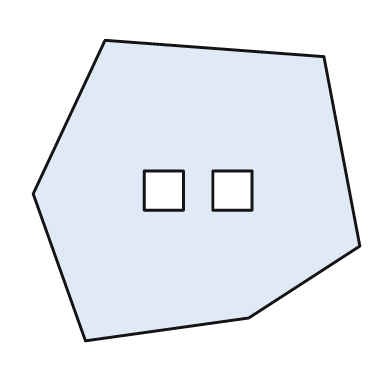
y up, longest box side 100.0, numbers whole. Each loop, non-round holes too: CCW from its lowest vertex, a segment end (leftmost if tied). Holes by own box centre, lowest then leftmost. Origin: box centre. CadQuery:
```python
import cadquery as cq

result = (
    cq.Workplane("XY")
    .moveTo(-34.0, -46.0)
    .lineTo(16.0, -39.0)
    .lineTo(50.0, -17.0)
    .lineTo(39.0, 41.0)
    .lineTo(-28.0, 46.0)
    .lineTo(-50.0, -1.0)
    .close()
    .moveTo(-16.0, -6.0)
    .lineTo(-4.0, -6.0)
    .lineTo(-4.0, 6.0)
    .lineTo(-16.0, 6.0)
    .close()
    .moveTo(5.0, -6.0)
    .lineTo(17.0, -6.0)
    .lineTo(17.0, 6.0)
    .lineTo(5.0, 6.0)
    .close()
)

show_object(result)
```